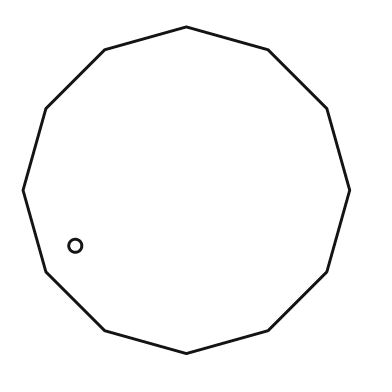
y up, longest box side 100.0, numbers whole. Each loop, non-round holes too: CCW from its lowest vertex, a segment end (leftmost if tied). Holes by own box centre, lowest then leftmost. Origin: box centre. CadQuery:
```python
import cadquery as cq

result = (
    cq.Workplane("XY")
    .moveTo(0.0, -50.0)
    .lineTo(25.0, -43.0)
    .lineTo(43.0, -25.0)
    .lineTo(50.0, 0.0)
    .lineTo(43.0, 25.0)
    .lineTo(25.0, 43.0)
    .lineTo(0.0, 50.0)
    .lineTo(-25.0, 43.0)
    .lineTo(-43.0, 25.0)
    .lineTo(-50.0, 0.0)
    .lineTo(-43.0, -25.0)
    .lineTo(-25.0, -43.0)
    .close()
    .moveTo(-34.0, -17.0)
    .circle(2.0)
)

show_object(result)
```